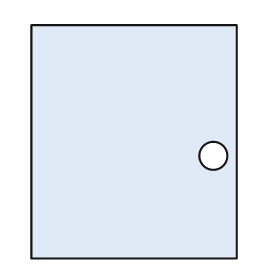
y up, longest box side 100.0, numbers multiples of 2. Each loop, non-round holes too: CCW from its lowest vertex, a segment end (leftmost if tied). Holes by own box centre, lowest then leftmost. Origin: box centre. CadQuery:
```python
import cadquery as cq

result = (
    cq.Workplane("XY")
    .moveTo(-44.0, -50.0)
    .lineTo(44.0, -50.0)
    .lineTo(44.0, 50.0)
    .lineTo(-44.0, 50.0)
    .close()
    .moveTo(34.0, -6.0)
    .circle(6.0)
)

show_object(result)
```